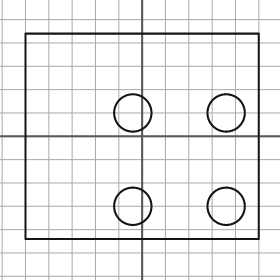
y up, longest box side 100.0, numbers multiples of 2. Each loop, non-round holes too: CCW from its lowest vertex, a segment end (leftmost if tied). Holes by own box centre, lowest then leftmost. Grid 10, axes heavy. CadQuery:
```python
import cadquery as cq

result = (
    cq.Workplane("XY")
    .moveTo(-50.0, -44.0)
    .lineTo(50.0, -44.0)
    .lineTo(50.0, 44.0)
    .lineTo(-50.0, 44.0)
    .close()
    .moveTo(-4.0, -30.0)
    .circle(8.0)
    .moveTo(36.0, -30.0)
    .circle(8.0)
    .moveTo(-4.0, 10.0)
    .circle(8.0)
    .moveTo(36.0, 10.0)
    .circle(8.0)
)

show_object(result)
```